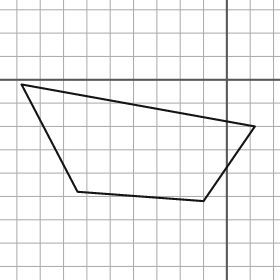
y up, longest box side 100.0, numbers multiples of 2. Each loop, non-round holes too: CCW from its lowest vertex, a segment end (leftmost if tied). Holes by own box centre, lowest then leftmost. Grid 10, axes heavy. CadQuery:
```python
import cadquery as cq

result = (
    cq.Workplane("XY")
    .moveTo(-10.0, -52.0)
    .lineTo(12.0, -20.0)
    .lineTo(-88.0, -2.0)
    .lineTo(-64.0, -48.0)
    .close()
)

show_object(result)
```